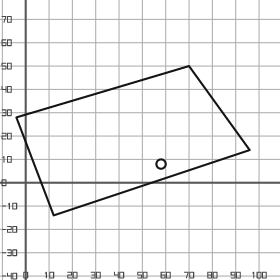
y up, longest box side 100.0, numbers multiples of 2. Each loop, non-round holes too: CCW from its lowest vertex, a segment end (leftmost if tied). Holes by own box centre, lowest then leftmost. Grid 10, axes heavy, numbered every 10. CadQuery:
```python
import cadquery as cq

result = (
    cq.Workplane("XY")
    .moveTo(12.0, -14.0)
    .lineTo(96.0, 14.0)
    .lineTo(70.0, 50.0)
    .lineTo(-4.0, 28.0)
    .close()
    .moveTo(58.0, 8.0)
    .circle(2.0)
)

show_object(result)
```